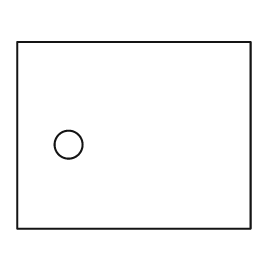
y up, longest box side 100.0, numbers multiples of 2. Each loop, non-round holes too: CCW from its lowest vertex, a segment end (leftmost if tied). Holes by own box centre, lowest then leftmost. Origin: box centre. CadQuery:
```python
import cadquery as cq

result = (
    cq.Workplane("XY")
    .moveTo(-50.0, -40.0)
    .lineTo(50.0, -40.0)
    .lineTo(50.0, 40.0)
    .lineTo(-50.0, 40.0)
    .close()
    .moveTo(-28.0, -4.0)
    .circle(6.0)
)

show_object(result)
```